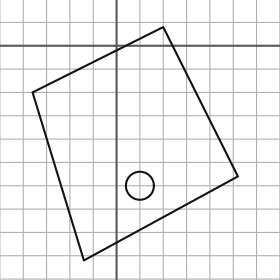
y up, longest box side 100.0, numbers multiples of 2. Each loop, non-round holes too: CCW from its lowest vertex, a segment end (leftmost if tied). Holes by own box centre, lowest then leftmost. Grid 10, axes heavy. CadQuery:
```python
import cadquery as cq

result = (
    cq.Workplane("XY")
    .moveTo(-14.0, -92.0)
    .lineTo(52.0, -56.0)
    .lineTo(20.0, 8.0)
    .lineTo(-36.0, -20.0)
    .close()
    .moveTo(10.0, -60.0)
    .circle(6.0)
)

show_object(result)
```